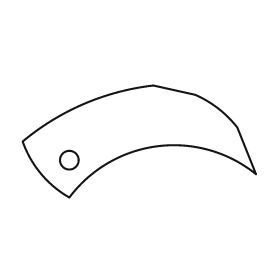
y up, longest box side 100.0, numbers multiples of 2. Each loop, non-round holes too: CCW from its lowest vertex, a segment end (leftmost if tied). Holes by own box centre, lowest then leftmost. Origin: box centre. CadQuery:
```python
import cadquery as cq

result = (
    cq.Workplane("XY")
    .moveTo(-30.0, -24.0)
    .threePointArc((8.0, -2.0), (50.0, -14.0))
    .lineTo(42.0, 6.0)
    .threePointArc((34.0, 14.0), (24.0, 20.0))
    .lineTo(6.0, 24.0)
    .threePointArc((-24.0, 16.0), (-50.0, 0.0))
    .threePointArc((-42.0, -14.0), (-30.0, -24.0))
    .close()
    .moveTo(-30.0, -8.0)
    .circle(4.0)
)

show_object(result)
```